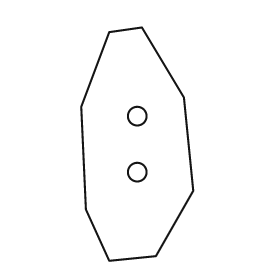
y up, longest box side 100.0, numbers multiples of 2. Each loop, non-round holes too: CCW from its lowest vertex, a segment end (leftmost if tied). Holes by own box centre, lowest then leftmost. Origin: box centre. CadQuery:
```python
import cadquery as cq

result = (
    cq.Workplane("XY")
    .moveTo(-12.0, -50.0)
    .lineTo(8.0, -48.0)
    .lineTo(24.0, -20.0)
    .lineTo(20.0, 20.0)
    .lineTo(2.0, 50.0)
    .lineTo(-12.0, 48.0)
    .lineTo(-24.0, 16.0)
    .lineTo(-22.0, -28.0)
    .close()
    .moveTo(0.0, -12.0)
    .circle(4.0)
    .moveTo(0.0, 12.0)
    .circle(4.0)
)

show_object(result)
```